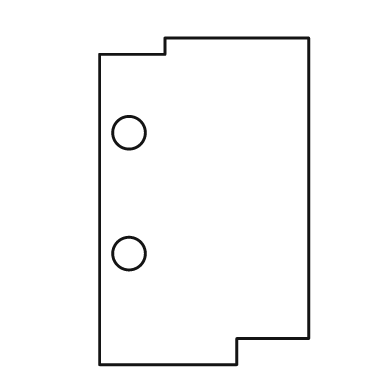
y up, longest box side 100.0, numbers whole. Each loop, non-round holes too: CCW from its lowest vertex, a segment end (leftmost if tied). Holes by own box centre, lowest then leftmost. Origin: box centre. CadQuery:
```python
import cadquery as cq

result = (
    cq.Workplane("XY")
    .moveTo(-32.0, -50.0)
    .lineTo(10.0, -50.0)
    .lineTo(10.0, -42.0)
    .lineTo(32.0, -42.0)
    .lineTo(32.0, 50.0)
    .lineTo(-12.0, 50.0)
    .lineTo(-12.0, 45.0)
    .lineTo(-32.0, 45.0)
    .close()
    .moveTo(-23.0, -16.0)
    .circle(5.0)
    .moveTo(-23.0, 21.0)
    .circle(5.0)
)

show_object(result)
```